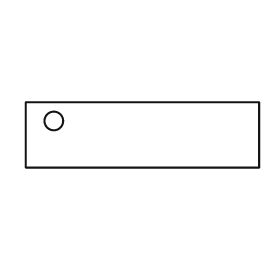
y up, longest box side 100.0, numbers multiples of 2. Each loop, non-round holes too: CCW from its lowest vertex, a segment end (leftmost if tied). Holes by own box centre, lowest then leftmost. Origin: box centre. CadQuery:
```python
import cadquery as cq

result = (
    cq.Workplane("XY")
    .moveTo(-50.0, -14.0)
    .lineTo(50.0, -14.0)
    .lineTo(50.0, 14.0)
    .lineTo(-50.0, 14.0)
    .close()
    .moveTo(-38.0, 6.0)
    .circle(4.0)
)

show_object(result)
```